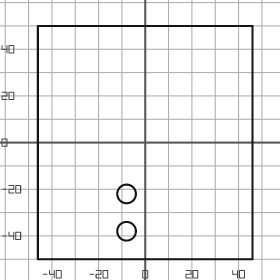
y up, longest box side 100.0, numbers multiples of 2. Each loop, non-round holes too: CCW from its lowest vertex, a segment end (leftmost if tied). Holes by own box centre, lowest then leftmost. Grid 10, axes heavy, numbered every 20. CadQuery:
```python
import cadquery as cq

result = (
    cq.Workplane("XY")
    .moveTo(-46.0, -50.0)
    .lineTo(46.0, -50.0)
    .lineTo(46.0, 50.0)
    .lineTo(-46.0, 50.0)
    .close()
    .moveTo(-8.0, -38.0)
    .circle(4.0)
    .moveTo(-8.0, -22.0)
    .circle(4.0)
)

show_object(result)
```